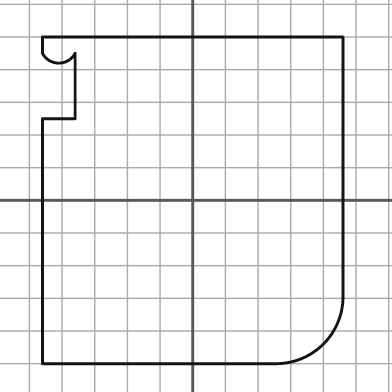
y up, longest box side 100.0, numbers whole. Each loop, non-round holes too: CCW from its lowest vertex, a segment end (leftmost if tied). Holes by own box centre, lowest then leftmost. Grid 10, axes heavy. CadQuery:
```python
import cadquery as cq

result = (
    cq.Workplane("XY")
    .moveTo(-46.0, -50.0)
    .lineTo(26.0, -50.0)
    .threePointArc((40.0, -44.0), (46.0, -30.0))
    .lineTo(46.0, 50.0)
    .lineTo(-46.0, 50.0)
    .lineTo(-46.0, 45.0)
    .threePointArc((-41.0, 42.0), (-36.0, 45.0))
    .lineTo(-36.0, 25.0)
    .lineTo(-46.0, 25.0)
    .close()
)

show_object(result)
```